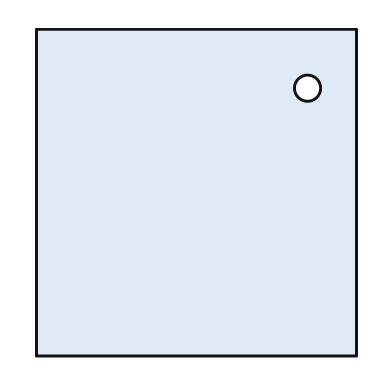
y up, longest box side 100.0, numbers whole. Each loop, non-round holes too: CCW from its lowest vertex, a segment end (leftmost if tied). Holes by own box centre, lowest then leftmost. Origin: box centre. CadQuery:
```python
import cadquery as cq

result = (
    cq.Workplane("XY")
    .moveTo(-49.0, -50.0)
    .lineTo(49.0, -50.0)
    .lineTo(49.0, 50.0)
    .lineTo(-49.0, 50.0)
    .close()
    .moveTo(34.0, 32.0)
    .circle(4.0)
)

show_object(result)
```